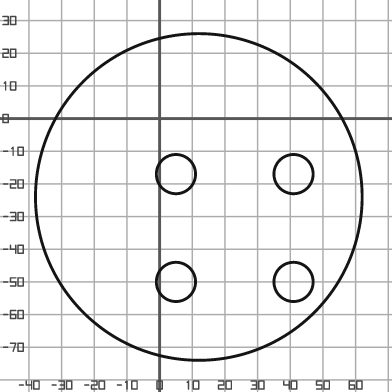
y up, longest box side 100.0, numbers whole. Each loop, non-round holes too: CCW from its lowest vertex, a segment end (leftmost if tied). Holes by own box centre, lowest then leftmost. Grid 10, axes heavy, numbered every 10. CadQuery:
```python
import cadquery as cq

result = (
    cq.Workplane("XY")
    .moveTo(12.0, -24.0)
    .circle(50.0)
    .moveTo(5.0, -50.0)
    .circle(6.0)
    .moveTo(41.0, -50.0)
    .circle(6.0)
    .moveTo(5.0, -17.0)
    .circle(6.0)
    .moveTo(41.0, -17.0)
    .circle(6.0)
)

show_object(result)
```